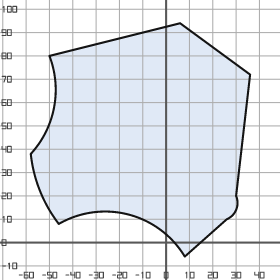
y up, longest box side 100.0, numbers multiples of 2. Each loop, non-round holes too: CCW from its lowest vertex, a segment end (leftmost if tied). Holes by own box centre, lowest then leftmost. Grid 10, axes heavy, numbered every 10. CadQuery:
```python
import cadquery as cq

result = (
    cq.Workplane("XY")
    .moveTo(8.0, -6.0)
    .lineTo(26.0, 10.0)
    .threePointArc((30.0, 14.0), (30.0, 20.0))
    .lineTo(36.0, 72.0)
    .lineTo(6.0, 94.0)
    .lineTo(-50.0, 80.0)
    .threePointArc((-48.0, 58.0), (-58.0, 38.0))
    .threePointArc((-54.0, 22.0), (-46.0, 8.0))
    .threePointArc((-16.0, 12.0), (8.0, -6.0))
    .close()
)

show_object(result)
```